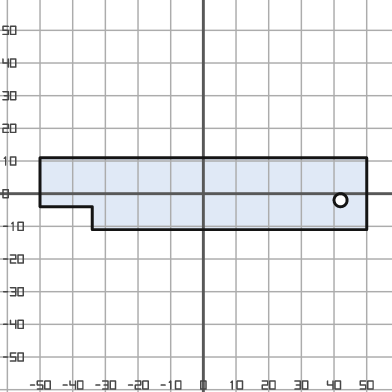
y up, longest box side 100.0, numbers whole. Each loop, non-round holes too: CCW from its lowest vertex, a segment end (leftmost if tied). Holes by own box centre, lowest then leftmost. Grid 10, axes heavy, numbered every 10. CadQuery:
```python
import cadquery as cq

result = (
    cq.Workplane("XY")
    .moveTo(-34.0, -11.0)
    .lineTo(50.0, -11.0)
    .lineTo(50.0, 11.0)
    .lineTo(-50.0, 11.0)
    .lineTo(-50.0, -4.0)
    .lineTo(-34.0, -4.0)
    .close()
    .moveTo(42.0, -2.0)
    .circle(2.0)
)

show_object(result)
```